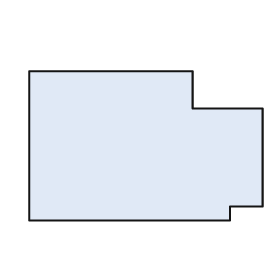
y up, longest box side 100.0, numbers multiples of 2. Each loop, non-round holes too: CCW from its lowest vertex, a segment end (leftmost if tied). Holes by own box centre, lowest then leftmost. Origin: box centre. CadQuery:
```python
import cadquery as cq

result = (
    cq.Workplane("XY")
    .moveTo(-50.0, -32.0)
    .lineTo(36.0, -32.0)
    .lineTo(36.0, -26.0)
    .lineTo(50.0, -26.0)
    .lineTo(50.0, 16.0)
    .lineTo(20.0, 16.0)
    .lineTo(20.0, 32.0)
    .lineTo(-50.0, 32.0)
    .close()
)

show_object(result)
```